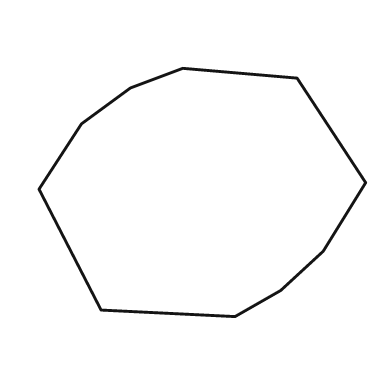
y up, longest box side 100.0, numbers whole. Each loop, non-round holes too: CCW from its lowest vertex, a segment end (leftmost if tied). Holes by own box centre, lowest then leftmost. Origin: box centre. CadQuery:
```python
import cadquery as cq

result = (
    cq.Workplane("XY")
    .moveTo(10.0, -38.0)
    .lineTo(24.0, -30.0)
    .lineTo(37.0, -18.0)
    .lineTo(50.0, 3.0)
    .lineTo(29.0, 35.0)
    .lineTo(-6.0, 38.0)
    .lineTo(-22.0, 32.0)
    .lineTo(-37.0, 21.0)
    .lineTo(-50.0, 1.0)
    .lineTo(-31.0, -36.0)
    .close()
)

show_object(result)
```